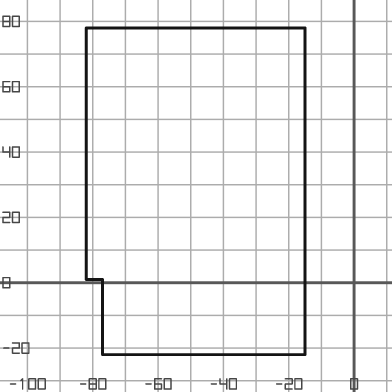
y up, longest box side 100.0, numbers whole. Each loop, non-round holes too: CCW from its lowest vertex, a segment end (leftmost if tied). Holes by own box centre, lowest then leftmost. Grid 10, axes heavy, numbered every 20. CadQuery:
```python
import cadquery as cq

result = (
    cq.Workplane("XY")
    .moveTo(-77.0, -22.0)
    .lineTo(-15.0, -22.0)
    .lineTo(-15.0, 78.0)
    .lineTo(-82.0, 78.0)
    .lineTo(-82.0, 1.0)
    .lineTo(-77.0, 1.0)
    .close()
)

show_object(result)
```